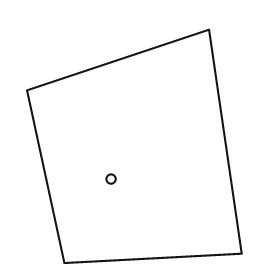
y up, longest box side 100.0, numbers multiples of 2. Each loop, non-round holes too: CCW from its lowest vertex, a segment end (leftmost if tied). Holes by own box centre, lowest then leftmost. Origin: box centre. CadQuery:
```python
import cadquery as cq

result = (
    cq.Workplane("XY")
    .moveTo(-30.0, -50.0)
    .lineTo(46.0, -46.0)
    .lineTo(32.0, 50.0)
    .lineTo(-46.0, 24.0)
    .close()
    .moveTo(-10.0, -14.0)
    .circle(2.0)
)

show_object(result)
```